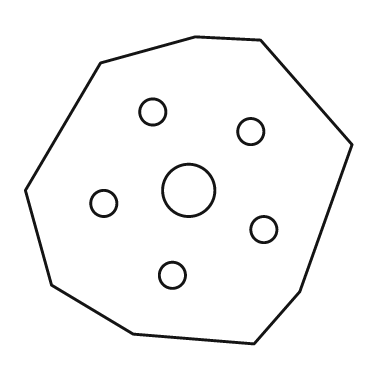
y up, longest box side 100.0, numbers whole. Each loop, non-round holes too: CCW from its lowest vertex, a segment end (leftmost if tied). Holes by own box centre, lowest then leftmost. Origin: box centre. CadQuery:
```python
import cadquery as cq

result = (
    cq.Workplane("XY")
    .moveTo(20.0, -47.0)
    .lineTo(34.0, -31.0)
    .lineTo(50.0, 14.0)
    .lineTo(22.0, 46.0)
    .lineTo(2.0, 47.0)
    .lineTo(-27.0, 39.0)
    .lineTo(-50.0, 0.0)
    .lineTo(-42.0, -29.0)
    .lineTo(-17.0, -44.0)
    .close()
    .moveTo(-5.0, -26.0)
    .circle(4.0)
    .moveTo(23.0, -12.0)
    .circle(4.0)
    .moveTo(-26.0, -4.0)
    .circle(4.0)
    .moveTo(0.0, 0.0)
    .circle(8.0)
    .moveTo(19.0, 18.0)
    .circle(4.0)
    .moveTo(-11.0, 24.0)
    .circle(4.0)
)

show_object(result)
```